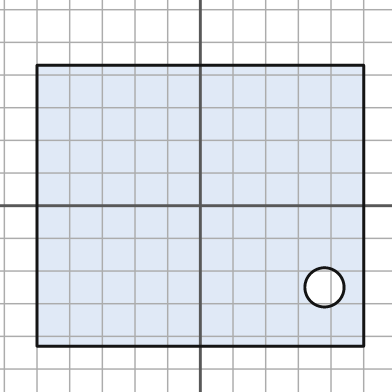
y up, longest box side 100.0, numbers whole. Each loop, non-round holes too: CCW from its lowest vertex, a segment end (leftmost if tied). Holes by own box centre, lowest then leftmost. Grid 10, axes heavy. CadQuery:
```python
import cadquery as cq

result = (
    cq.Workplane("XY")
    .moveTo(-50.0, -43.0)
    .lineTo(50.0, -43.0)
    .lineTo(50.0, 43.0)
    .lineTo(-50.0, 43.0)
    .close()
    .moveTo(38.0, -25.0)
    .circle(6.0)
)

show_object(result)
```